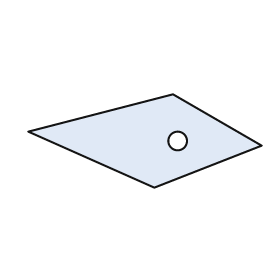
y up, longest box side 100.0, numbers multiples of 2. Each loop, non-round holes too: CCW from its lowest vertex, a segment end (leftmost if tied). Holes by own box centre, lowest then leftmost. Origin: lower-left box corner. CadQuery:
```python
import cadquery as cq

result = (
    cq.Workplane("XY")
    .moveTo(54.0, 0.0)
    .lineTo(100.0, 18.0)
    .lineTo(62.0, 40.0)
    .lineTo(0.0, 24.0)
    .close()
    .moveTo(64.0, 20.0)
    .circle(4.0)
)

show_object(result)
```